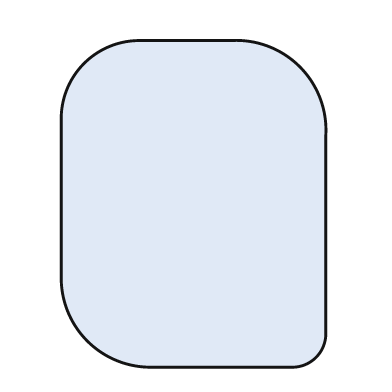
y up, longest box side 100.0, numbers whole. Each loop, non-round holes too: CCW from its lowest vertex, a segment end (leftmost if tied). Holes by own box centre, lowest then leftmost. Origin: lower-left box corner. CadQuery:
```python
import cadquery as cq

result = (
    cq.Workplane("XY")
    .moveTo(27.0, 0.0)
    .lineTo(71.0, 0.0)
    .threePointArc((78.0, 3.0), (81.0, 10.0))
    .lineTo(81.0, 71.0)
    .threePointArc((73.0, 92.0), (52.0, 100.0))
    .lineTo(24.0, 100.0)
    .threePointArc((7.0, 93.0), (0.0, 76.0))
    .lineTo(0.0, 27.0)
    .threePointArc((8.0, 8.0), (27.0, 0.0))
    .close()
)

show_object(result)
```